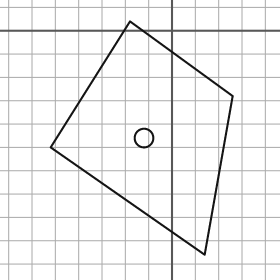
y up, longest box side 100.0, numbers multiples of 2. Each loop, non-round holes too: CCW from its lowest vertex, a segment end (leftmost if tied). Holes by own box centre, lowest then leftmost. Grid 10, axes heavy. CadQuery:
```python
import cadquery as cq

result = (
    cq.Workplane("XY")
    .moveTo(14.0, -96.0)
    .lineTo(26.0, -28.0)
    .lineTo(-18.0, 4.0)
    .lineTo(-52.0, -50.0)
    .close()
    .moveTo(-12.0, -46.0)
    .circle(4.0)
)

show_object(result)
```